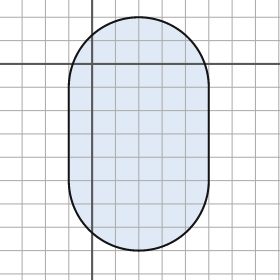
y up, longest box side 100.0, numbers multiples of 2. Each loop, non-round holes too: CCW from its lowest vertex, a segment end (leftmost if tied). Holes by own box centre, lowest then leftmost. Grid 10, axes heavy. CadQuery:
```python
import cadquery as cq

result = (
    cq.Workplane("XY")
    .moveTo(-10.0, -50.0)
    .threePointArc((20.0, -80.0), (50.0, -50.0))
    .lineTo(50.0, -10.0)
    .threePointArc((20.0, 20.0), (-10.0, -10.0))
    .close()
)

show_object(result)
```